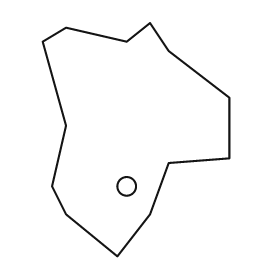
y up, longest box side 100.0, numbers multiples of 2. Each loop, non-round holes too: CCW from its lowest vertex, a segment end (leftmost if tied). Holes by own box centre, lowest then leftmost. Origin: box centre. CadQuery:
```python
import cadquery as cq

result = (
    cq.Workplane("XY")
    .moveTo(-8.0, -50.0)
    .lineTo(6.0, -32.0)
    .lineTo(14.0, -10.0)
    .lineTo(40.0, -8.0)
    .lineTo(40.0, 18.0)
    .lineTo(14.0, 38.0)
    .lineTo(6.0, 50.0)
    .lineTo(-4.0, 42.0)
    .lineTo(-30.0, 48.0)
    .lineTo(-40.0, 42.0)
    .lineTo(-30.0, 6.0)
    .lineTo(-36.0, -20.0)
    .lineTo(-30.0, -32.0)
    .close()
    .moveTo(-4.0, -20.0)
    .circle(4.0)
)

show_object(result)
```